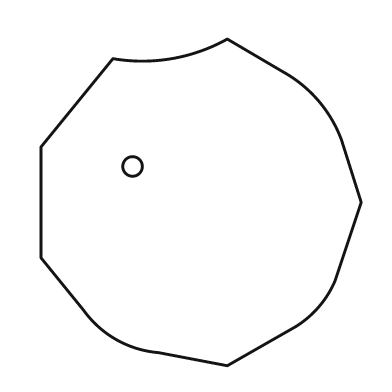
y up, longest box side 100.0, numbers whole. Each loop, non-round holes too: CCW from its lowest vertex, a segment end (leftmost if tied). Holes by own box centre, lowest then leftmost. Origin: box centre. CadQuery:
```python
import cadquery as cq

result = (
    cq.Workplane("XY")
    .moveTo(8.0, -50.0)
    .lineTo(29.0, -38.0)
    .threePointArc((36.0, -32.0), (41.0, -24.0))
    .lineTo(49.0, 0.0)
    .lineTo(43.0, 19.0)
    .threePointArc((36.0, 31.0), (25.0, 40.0))
    .lineTo(8.0, 50.0)
    .threePointArc((-9.0, 44.0), (-27.0, 44.0))
    .lineTo(-49.0, 17.0)
    .lineTo(-49.0, -17.0)
    .lineTo(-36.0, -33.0)
    .threePointArc((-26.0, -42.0), (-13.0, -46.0))
    .close()
    .moveTo(-21.0, 11.0)
    .circle(3.0)
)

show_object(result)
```